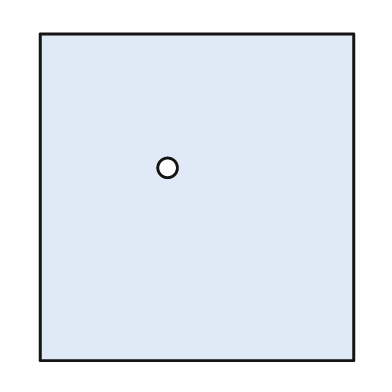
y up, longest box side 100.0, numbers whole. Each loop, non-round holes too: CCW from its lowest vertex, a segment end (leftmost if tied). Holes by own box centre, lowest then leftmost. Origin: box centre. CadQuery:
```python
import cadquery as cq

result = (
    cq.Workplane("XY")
    .moveTo(-48.0, -50.0)
    .lineTo(48.0, -50.0)
    .lineTo(48.0, 50.0)
    .lineTo(-48.0, 50.0)
    .close()
    .moveTo(-9.0, 9.0)
    .circle(3.0)
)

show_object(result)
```